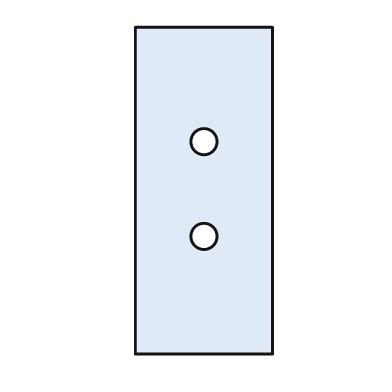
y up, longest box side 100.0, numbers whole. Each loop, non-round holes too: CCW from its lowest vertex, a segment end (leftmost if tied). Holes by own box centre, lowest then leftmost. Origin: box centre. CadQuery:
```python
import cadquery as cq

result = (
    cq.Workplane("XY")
    .moveTo(-21.0, -50.0)
    .lineTo(21.0, -50.0)
    .lineTo(21.0, 50.0)
    .lineTo(-21.0, 50.0)
    .close()
    .moveTo(0.0, -14.0)
    .circle(4.0)
    .moveTo(0.0, 15.0)
    .circle(4.0)
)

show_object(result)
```